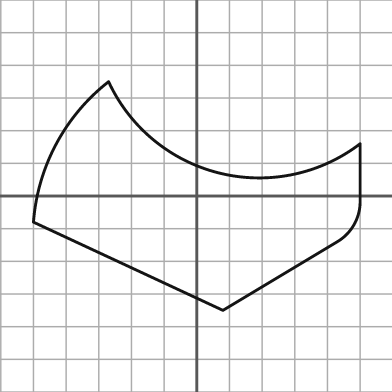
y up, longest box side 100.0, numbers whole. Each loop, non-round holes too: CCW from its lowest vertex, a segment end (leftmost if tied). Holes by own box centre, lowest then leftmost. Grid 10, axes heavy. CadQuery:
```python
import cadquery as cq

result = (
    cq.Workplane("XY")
    .moveTo(8.0, -35.0)
    .lineTo(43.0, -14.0)
    .threePointArc((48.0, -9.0), (50.0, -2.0))
    .lineTo(50.0, 16.0)
    .threePointArc((7.0, 7.0), (-27.0, 35.0))
    .threePointArc((-43.0, 16.0), (-50.0, -8.0))
    .close()
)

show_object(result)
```